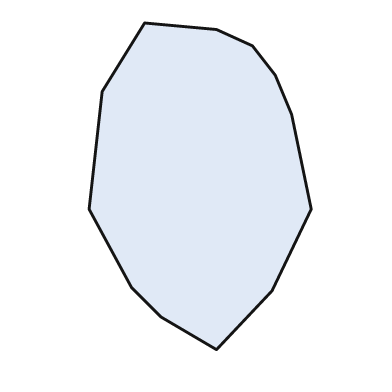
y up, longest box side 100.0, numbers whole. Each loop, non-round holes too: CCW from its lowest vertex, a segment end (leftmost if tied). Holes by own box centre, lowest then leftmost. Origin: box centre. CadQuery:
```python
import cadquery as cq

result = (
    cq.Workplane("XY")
    .moveTo(5.0, -50.0)
    .lineTo(22.0, -32.0)
    .lineTo(34.0, -7.0)
    .lineTo(28.0, 22.0)
    .lineTo(23.0, 34.0)
    .lineTo(16.0, 43.0)
    .lineTo(5.0, 48.0)
    .lineTo(-17.0, 50.0)
    .lineTo(-30.0, 29.0)
    .lineTo(-34.0, -7.0)
    .lineTo(-21.0, -31.0)
    .lineTo(-12.0, -40.0)
    .close()
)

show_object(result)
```